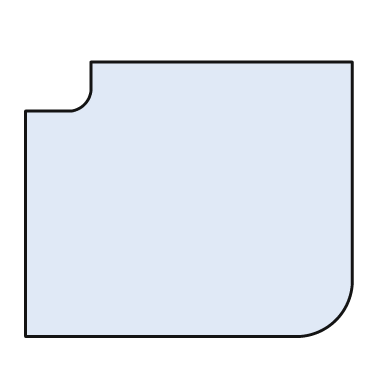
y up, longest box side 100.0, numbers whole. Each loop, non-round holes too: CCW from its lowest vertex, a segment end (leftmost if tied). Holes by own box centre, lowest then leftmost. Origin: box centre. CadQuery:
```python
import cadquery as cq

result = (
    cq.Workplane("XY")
    .moveTo(-50.0, -42.0)
    .lineTo(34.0, -42.0)
    .threePointArc((45.0, -37.0), (50.0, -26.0))
    .lineTo(50.0, 42.0)
    .lineTo(-30.0, 42.0)
    .lineTo(-30.0, 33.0)
    .threePointArc((-32.0, 29.0), (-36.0, 27.0))
    .lineTo(-50.0, 27.0)
    .close()
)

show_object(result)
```